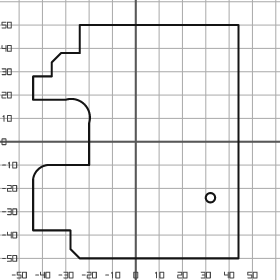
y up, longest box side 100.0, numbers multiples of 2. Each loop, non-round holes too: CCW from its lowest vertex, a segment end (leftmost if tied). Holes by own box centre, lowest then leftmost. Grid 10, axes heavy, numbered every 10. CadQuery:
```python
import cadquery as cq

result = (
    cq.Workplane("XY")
    .moveTo(-24.0, -50.0)
    .lineTo(44.0, -50.0)
    .lineTo(44.0, 50.0)
    .lineTo(-24.0, 50.0)
    .lineTo(-24.0, 38.0)
    .lineTo(-32.0, 38.0)
    .lineTo(-36.0, 34.0)
    .lineTo(-36.0, 28.0)
    .lineTo(-44.0, 28.0)
    .lineTo(-44.0, 18.0)
    .lineTo(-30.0, 18.0)
    .threePointArc((-22.0, 16.0), (-20.0, 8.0))
    .lineTo(-20.0, -10.0)
    .lineTo(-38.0, -10.0)
    .threePointArc((-42.0, -12.0), (-44.0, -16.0))
    .lineTo(-44.0, -38.0)
    .lineTo(-28.0, -38.0)
    .lineTo(-28.0, -46.0)
    .close()
    .moveTo(32.0, -24.0)
    .circle(2.0)
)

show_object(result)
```